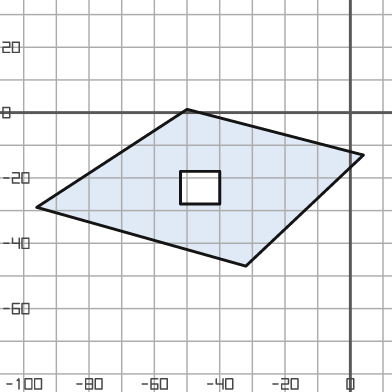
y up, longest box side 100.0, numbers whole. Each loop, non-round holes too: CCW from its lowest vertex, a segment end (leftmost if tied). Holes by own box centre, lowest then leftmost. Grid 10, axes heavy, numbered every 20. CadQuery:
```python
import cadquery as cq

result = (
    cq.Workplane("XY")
    .moveTo(-32.0, -47.0)
    .lineTo(4.0, -13.0)
    .lineTo(-50.0, 1.0)
    .lineTo(-96.0, -29.0)
    .close()
    .moveTo(-52.0, -28.0)
    .lineTo(-40.0, -28.0)
    .lineTo(-40.0, -18.0)
    .lineTo(-52.0, -18.0)
    .close()
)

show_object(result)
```